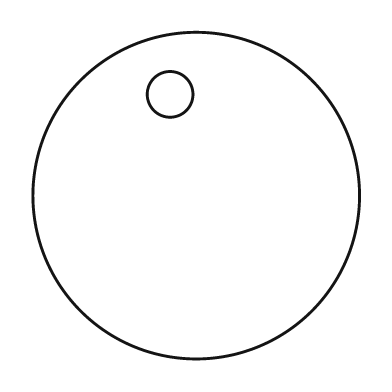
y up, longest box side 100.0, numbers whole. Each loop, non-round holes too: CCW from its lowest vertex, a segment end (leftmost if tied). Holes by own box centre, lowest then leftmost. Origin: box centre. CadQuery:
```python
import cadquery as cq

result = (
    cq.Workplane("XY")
    .moveTo(0.0, 0.0)
    .circle(50.0)
    .moveTo(-8.0, 31.0)
    .circle(7.0)
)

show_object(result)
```